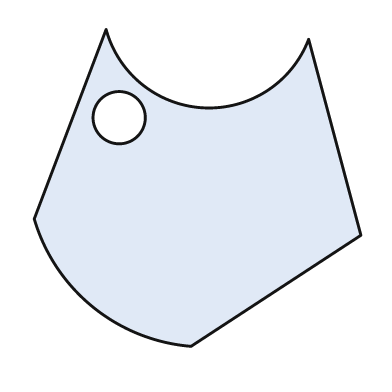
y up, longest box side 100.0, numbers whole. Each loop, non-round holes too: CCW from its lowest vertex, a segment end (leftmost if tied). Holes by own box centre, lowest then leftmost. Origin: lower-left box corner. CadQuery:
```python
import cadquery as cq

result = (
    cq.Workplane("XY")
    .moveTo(48.0, 0.0)
    .lineTo(100.0, 34.0)
    .lineTo(84.0, 94.0)
    .threePointArc((52.0, 73.0), (22.0, 97.0))
    .lineTo(0.0, 39.0)
    .threePointArc((18.0, 12.0), (48.0, 0.0))
    .close()
    .moveTo(26.0, 70.0)
    .circle(8.0)
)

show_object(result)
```